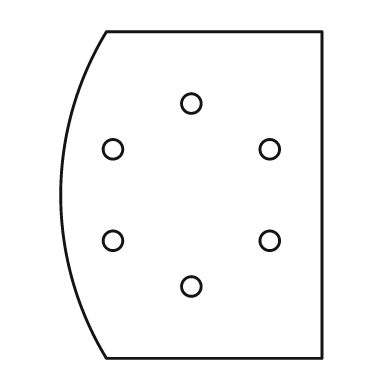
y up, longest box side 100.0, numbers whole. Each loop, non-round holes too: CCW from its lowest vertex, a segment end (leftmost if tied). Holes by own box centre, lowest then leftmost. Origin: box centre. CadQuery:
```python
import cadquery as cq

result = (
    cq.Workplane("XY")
    .moveTo(-26.0, -50.0)
    .lineTo(40.0, -50.0)
    .lineTo(40.0, 50.0)
    .lineTo(-26.0, 50.0)
    .threePointArc((-40.0, 0.0), (-26.0, -50.0))
    .close()
    .moveTo(0.0, -28.0)
    .circle(3.0)
    .moveTo(-24.0, -14.0)
    .circle(3.0)
    .moveTo(24.0, -14.0)
    .circle(3.0)
    .moveTo(-24.0, 14.0)
    .circle(3.0)
    .moveTo(24.0, 14.0)
    .circle(3.0)
    .moveTo(0.0, 28.0)
    .circle(3.0)
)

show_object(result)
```